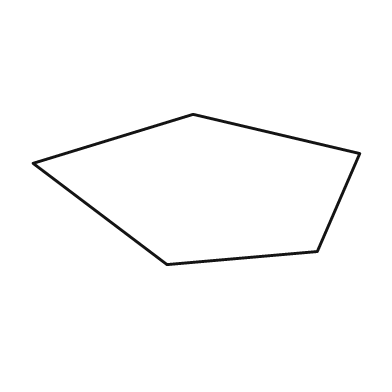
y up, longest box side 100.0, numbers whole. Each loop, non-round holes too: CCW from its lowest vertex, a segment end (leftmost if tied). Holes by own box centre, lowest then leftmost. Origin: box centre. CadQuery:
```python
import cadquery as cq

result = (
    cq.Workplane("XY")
    .moveTo(-9.0, -23.0)
    .lineTo(37.0, -19.0)
    .lineTo(50.0, 11.0)
    .lineTo(-1.0, 23.0)
    .lineTo(-50.0, 8.0)
    .close()
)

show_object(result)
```